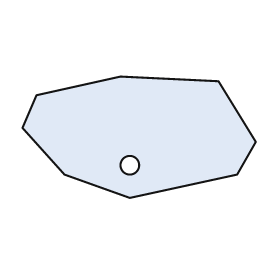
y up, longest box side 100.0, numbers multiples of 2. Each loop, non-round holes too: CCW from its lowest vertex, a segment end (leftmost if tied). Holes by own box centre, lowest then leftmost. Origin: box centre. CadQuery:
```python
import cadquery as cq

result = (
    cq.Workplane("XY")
    .moveTo(-4.0, -26.0)
    .lineTo(42.0, -16.0)
    .lineTo(50.0, -2.0)
    .lineTo(34.0, 24.0)
    .lineTo(-8.0, 26.0)
    .lineTo(-44.0, 18.0)
    .lineTo(-50.0, 4.0)
    .lineTo(-32.0, -16.0)
    .close()
    .moveTo(-4.0, -12.0)
    .circle(4.0)
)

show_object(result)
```